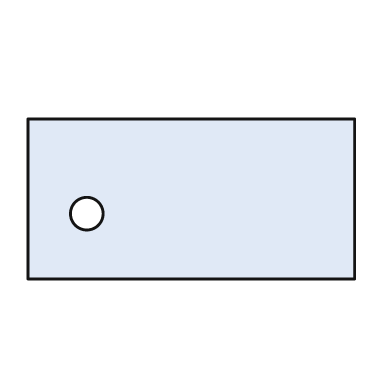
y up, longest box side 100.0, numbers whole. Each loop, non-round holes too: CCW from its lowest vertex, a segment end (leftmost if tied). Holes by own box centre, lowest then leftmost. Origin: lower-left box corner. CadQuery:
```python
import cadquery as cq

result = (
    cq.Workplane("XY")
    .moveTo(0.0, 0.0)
    .lineTo(100.0, 0.0)
    .lineTo(100.0, 49.0)
    .lineTo(0.0, 49.0)
    .close()
    .moveTo(18.0, 20.0)
    .circle(5.0)
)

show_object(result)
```